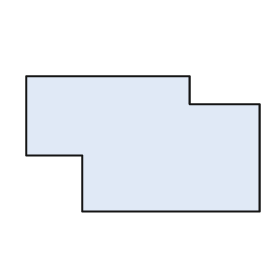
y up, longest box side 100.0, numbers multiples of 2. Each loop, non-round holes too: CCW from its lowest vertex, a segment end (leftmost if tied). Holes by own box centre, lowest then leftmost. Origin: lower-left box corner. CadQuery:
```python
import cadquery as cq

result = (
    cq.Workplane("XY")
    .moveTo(24.0, 0.0)
    .lineTo(100.0, 0.0)
    .lineTo(100.0, 46.0)
    .lineTo(70.0, 46.0)
    .lineTo(70.0, 58.0)
    .lineTo(0.0, 58.0)
    .lineTo(0.0, 24.0)
    .lineTo(24.0, 24.0)
    .close()
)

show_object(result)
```